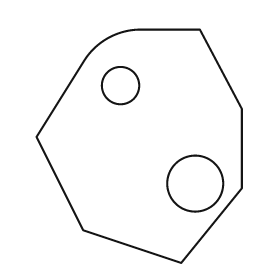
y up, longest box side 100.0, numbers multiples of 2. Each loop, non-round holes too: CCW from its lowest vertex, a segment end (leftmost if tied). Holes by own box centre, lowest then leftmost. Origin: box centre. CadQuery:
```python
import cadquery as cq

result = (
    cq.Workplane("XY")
    .moveTo(18.0, -50.0)
    .lineTo(44.0, -18.0)
    .lineTo(44.0, 16.0)
    .lineTo(26.0, 50.0)
    .lineTo(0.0, 50.0)
    .threePointArc((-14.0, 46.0), (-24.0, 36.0))
    .lineTo(-44.0, 4.0)
    .lineTo(-24.0, -36.0)
    .close()
    .moveTo(24.0, -16.0)
    .circle(12.0)
    .moveTo(-8.0, 26.0)
    .circle(8.0)
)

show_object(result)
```